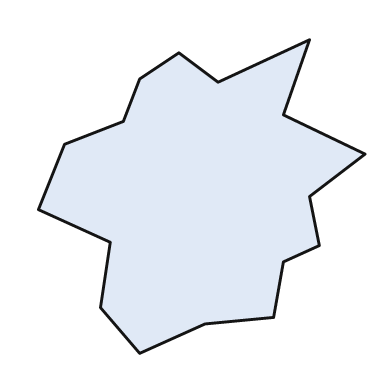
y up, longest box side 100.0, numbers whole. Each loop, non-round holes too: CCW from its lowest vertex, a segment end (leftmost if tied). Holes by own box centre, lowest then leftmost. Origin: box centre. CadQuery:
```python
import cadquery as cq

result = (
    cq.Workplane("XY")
    .moveTo(-19.0, -48.0)
    .lineTo(1.0, -39.0)
    .lineTo(22.0, -37.0)
    .lineTo(25.0, -20.0)
    .lineTo(36.0, -15.0)
    .lineTo(33.0, 0.0)
    .lineTo(50.0, 13.0)
    .lineTo(25.0, 25.0)
    .lineTo(33.0, 48.0)
    .lineTo(5.0, 35.0)
    .lineTo(-7.0, 44.0)
    .lineTo(-19.0, 36.0)
    .lineTo(-24.0, 23.0)
    .lineTo(-42.0, 16.0)
    .lineTo(-50.0, -4.0)
    .lineTo(-28.0, -14.0)
    .lineTo(-31.0, -34.0)
    .close()
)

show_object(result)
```